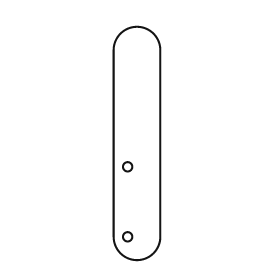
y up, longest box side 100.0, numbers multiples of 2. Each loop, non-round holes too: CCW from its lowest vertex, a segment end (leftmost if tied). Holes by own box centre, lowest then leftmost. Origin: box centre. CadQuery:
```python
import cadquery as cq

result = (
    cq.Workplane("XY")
    .moveTo(-10.0, -40.0)
    .threePointArc((0.0, -50.0), (10.0, -40.0))
    .lineTo(10.0, 40.0)
    .threePointArc((0.0, 50.0), (-10.0, 40.0))
    .close()
    .moveTo(-4.0, -40.0)
    .circle(2.0)
    .moveTo(-4.0, -10.0)
    .circle(2.0)
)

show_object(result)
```